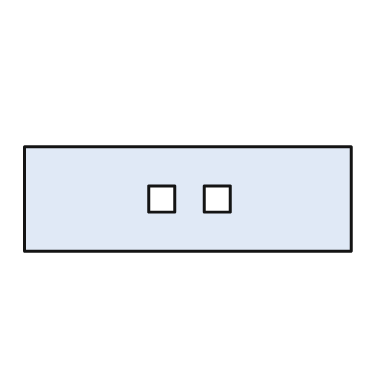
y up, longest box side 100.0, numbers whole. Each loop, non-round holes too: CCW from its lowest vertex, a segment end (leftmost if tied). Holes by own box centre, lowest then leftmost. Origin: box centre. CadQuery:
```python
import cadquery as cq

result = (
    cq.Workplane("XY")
    .moveTo(-50.0, -16.0)
    .lineTo(50.0, -16.0)
    .lineTo(50.0, 16.0)
    .lineTo(-50.0, 16.0)
    .close()
    .moveTo(-12.0, -4.0)
    .lineTo(-4.0, -4.0)
    .lineTo(-4.0, 4.0)
    .lineTo(-12.0, 4.0)
    .close()
    .moveTo(5.0, -4.0)
    .lineTo(13.0, -4.0)
    .lineTo(13.0, 4.0)
    .lineTo(5.0, 4.0)
    .close()
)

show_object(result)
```